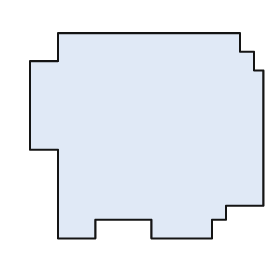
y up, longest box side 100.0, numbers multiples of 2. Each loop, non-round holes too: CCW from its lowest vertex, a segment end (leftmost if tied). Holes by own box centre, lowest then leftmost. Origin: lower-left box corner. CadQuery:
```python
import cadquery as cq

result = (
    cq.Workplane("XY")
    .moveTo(12.0, 0.0)
    .lineTo(28.0, 0.0)
    .lineTo(28.0, 8.0)
    .lineTo(52.0, 8.0)
    .lineTo(52.0, 0.0)
    .lineTo(78.0, 0.0)
    .lineTo(78.0, 8.0)
    .lineTo(84.0, 8.0)
    .lineTo(84.0, 14.0)
    .lineTo(100.0, 14.0)
    .lineTo(100.0, 72.0)
    .lineTo(96.0, 72.0)
    .lineTo(96.0, 80.0)
    .lineTo(90.0, 80.0)
    .lineTo(90.0, 88.0)
    .lineTo(12.0, 88.0)
    .lineTo(12.0, 76.0)
    .lineTo(0.0, 76.0)
    .lineTo(0.0, 38.0)
    .lineTo(12.0, 38.0)
    .close()
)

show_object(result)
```